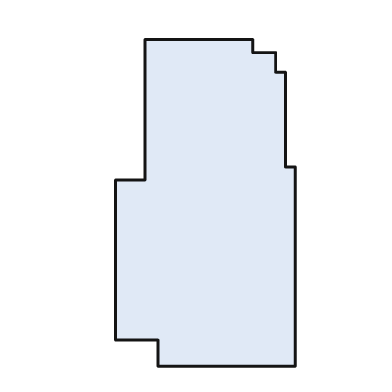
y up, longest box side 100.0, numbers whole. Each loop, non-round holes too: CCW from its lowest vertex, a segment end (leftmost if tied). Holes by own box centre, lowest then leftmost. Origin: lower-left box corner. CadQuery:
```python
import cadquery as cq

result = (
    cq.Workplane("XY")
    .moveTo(13.0, 0.0)
    .lineTo(55.0, 0.0)
    .lineTo(55.0, 61.0)
    .lineTo(52.0, 61.0)
    .lineTo(52.0, 90.0)
    .lineTo(49.0, 90.0)
    .lineTo(49.0, 96.0)
    .lineTo(42.0, 96.0)
    .lineTo(42.0, 100.0)
    .lineTo(9.0, 100.0)
    .lineTo(9.0, 57.0)
    .lineTo(0.0, 57.0)
    .lineTo(0.0, 8.0)
    .lineTo(13.0, 8.0)
    .close()
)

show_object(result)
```